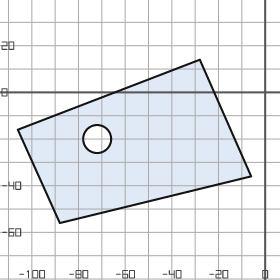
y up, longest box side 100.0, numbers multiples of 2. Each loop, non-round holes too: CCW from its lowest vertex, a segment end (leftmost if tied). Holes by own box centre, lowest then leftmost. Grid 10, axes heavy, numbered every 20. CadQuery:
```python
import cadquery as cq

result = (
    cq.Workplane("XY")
    .moveTo(-88.0, -56.0)
    .lineTo(-6.0, -36.0)
    .lineTo(-28.0, 14.0)
    .lineTo(-106.0, -16.0)
    .close()
    .moveTo(-72.0, -20.0)
    .circle(6.0)
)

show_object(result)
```